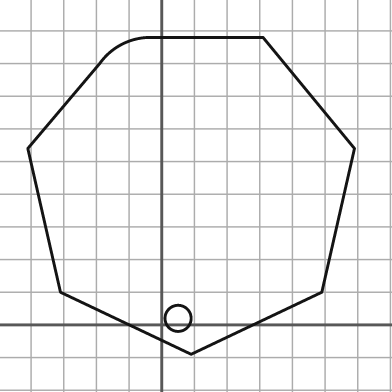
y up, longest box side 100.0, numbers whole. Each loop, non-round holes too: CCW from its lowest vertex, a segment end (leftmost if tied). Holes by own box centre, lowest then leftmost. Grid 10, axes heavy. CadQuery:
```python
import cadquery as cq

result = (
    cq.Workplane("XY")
    .moveTo(9.0, -9.0)
    .lineTo(49.0, 10.0)
    .lineTo(59.0, 54.0)
    .lineTo(31.0, 88.0)
    .lineTo(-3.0, 88.0)
    .threePointArc((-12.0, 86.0), (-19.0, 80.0))
    .lineTo(-41.0, 54.0)
    .lineTo(-31.0, 10.0)
    .close()
    .moveTo(5.0, 2.0)
    .circle(4.0)
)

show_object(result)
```